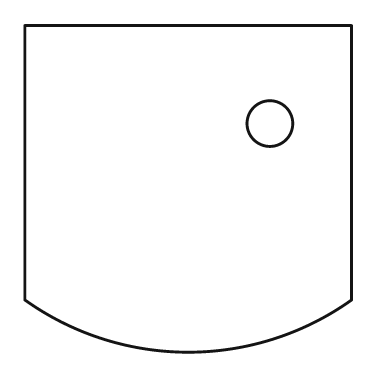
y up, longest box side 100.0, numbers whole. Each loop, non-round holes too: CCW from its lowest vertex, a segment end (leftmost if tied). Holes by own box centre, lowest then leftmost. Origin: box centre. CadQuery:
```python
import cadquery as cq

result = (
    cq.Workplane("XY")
    .moveTo(-50.0, -34.0)
    .threePointArc((0.0, -50.0), (50.0, -34.0))
    .lineTo(50.0, 50.0)
    .lineTo(-50.0, 50.0)
    .close()
    .moveTo(25.0, 20.0)
    .circle(7.0)
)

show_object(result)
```